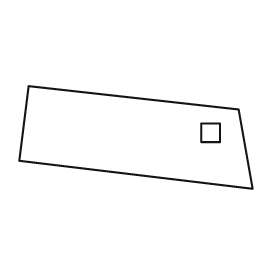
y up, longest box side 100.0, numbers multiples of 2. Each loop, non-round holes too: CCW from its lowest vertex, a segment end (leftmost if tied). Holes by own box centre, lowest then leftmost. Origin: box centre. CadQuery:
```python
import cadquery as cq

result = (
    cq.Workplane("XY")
    .moveTo(50.0, -22.0)
    .lineTo(44.0, 12.0)
    .lineTo(-46.0, 22.0)
    .lineTo(-50.0, -10.0)
    .close()
    .moveTo(28.0, -2.0)
    .lineTo(36.0, -2.0)
    .lineTo(36.0, 6.0)
    .lineTo(28.0, 6.0)
    .close()
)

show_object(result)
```